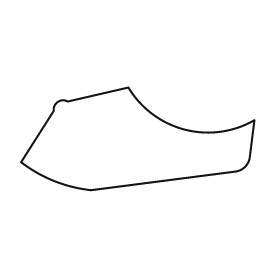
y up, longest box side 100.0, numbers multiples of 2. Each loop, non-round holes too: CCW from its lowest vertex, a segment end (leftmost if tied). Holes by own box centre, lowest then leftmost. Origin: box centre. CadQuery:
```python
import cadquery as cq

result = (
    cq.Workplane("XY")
    .moveTo(-20.0, -22.0)
    .lineTo(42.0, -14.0)
    .threePointArc((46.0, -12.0), (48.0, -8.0))
    .lineTo(50.0, 8.0)
    .threePointArc((20.0, 4.0), (-4.0, 22.0))
    .lineTo(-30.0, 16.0)
    .threePointArc((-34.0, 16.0), (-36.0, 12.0))
    .lineTo(-50.0, -10.0)
    .threePointArc((-36.0, -18.0), (-20.0, -22.0))
    .close()
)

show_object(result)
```